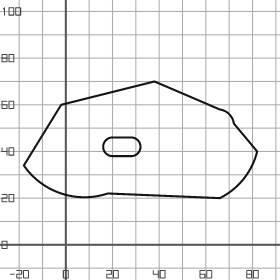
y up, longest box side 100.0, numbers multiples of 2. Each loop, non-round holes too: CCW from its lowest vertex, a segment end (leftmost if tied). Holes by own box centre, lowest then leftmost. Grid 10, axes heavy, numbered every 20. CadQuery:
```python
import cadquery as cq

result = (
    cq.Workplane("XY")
    .moveTo(66.0, 20.0)
    .threePointArc((76.0, 28.0), (82.0, 40.0))
    .lineTo(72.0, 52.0)
    .threePointArc((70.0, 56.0), (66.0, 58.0))
    .lineTo(38.0, 70.0)
    .lineTo(-2.0, 60.0)
    .lineTo(-18.0, 34.0)
    .threePointArc((-2.0, 22.0), (18.0, 22.0))
    .close()
    .moveTo(20.0, 38.0)
    .lineTo(28.0, 38.0)
    .threePointArc((32.0, 42.0), (28.0, 46.0))
    .lineTo(20.0, 46.0)
    .threePointArc((16.0, 42.0), (20.0, 38.0))
    .close()
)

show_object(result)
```